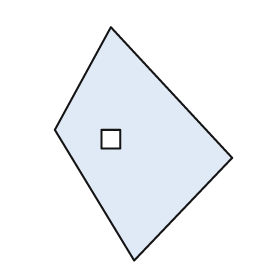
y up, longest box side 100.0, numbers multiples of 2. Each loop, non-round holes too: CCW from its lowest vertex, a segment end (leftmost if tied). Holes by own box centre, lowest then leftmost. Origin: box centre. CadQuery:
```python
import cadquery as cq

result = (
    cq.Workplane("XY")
    .moveTo(-4.0, -50.0)
    .lineTo(38.0, -6.0)
    .lineTo(-14.0, 50.0)
    .lineTo(-38.0, 6.0)
    .close()
    .moveTo(-18.0, -2.0)
    .lineTo(-10.0, -2.0)
    .lineTo(-10.0, 6.0)
    .lineTo(-18.0, 6.0)
    .close()
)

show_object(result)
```